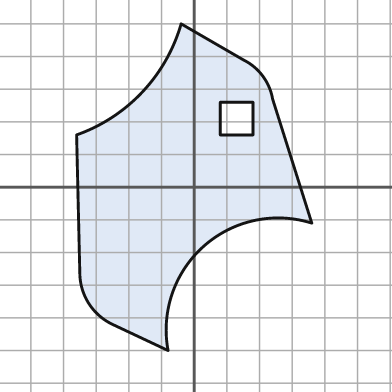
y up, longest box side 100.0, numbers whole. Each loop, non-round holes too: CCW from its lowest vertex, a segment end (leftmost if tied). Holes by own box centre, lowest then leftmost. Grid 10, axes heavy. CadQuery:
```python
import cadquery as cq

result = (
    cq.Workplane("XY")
    .moveTo(-8.0, -50.0)
    .threePointArc((3.0, -18.0), (36.0, -11.0))
    .lineTo(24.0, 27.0)
    .threePointArc((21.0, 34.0), (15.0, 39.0))
    .lineTo(-4.0, 50.0)
    .threePointArc((-16.0, 29.0), (-36.0, 16.0))
    .lineTo(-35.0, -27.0)
    .threePointArc((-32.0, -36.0), (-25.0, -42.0))
    .close()
    .moveTo(8.0, 16.0)
    .lineTo(18.0, 16.0)
    .lineTo(18.0, 26.0)
    .lineTo(8.0, 26.0)
    .close()
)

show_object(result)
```